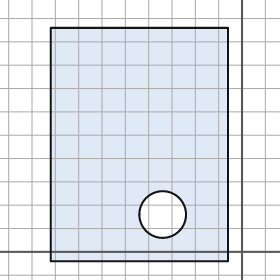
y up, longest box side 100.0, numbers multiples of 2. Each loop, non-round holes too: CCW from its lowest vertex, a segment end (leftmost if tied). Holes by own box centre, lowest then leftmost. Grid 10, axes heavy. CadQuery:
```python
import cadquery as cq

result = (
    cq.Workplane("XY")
    .moveTo(-82.0, -4.0)
    .lineTo(-6.0, -4.0)
    .lineTo(-6.0, 96.0)
    .lineTo(-82.0, 96.0)
    .close()
    .moveTo(-34.0, 16.0)
    .circle(10.0)
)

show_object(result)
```